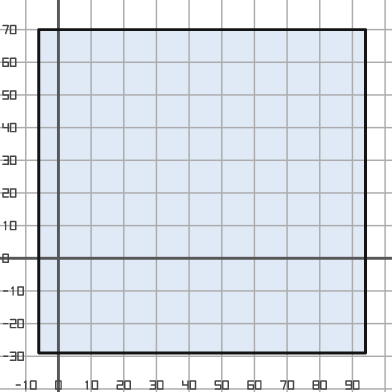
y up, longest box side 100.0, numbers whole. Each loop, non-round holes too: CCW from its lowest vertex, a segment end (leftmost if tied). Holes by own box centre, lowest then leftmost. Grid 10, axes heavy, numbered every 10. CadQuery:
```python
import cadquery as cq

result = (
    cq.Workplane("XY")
    .moveTo(-6.0, -29.0)
    .lineTo(94.0, -29.0)
    .lineTo(94.0, 70.0)
    .lineTo(-6.0, 70.0)
    .close()
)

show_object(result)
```